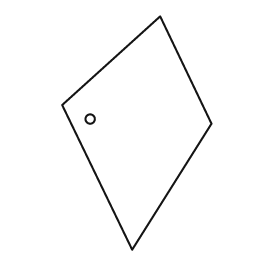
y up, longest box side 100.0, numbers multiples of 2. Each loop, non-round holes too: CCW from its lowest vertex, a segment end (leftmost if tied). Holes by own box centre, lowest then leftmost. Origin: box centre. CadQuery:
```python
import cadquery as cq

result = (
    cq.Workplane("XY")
    .moveTo(-2.0, -50.0)
    .lineTo(32.0, 4.0)
    .lineTo(10.0, 50.0)
    .lineTo(-32.0, 12.0)
    .close()
    .moveTo(-20.0, 6.0)
    .circle(2.0)
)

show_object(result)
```